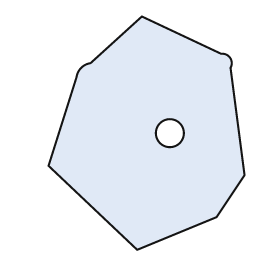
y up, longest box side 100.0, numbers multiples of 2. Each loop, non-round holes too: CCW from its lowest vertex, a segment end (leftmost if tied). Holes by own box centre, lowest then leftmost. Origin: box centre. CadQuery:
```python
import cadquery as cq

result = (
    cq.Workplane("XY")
    .moveTo(-4.0, -50.0)
    .lineTo(30.0, -36.0)
    .lineTo(42.0, -18.0)
    .lineTo(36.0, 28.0)
    .threePointArc((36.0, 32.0), (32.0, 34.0))
    .lineTo(-2.0, 50.0)
    .lineTo(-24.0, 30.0)
    .threePointArc((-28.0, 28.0), (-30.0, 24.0))
    .lineTo(-42.0, -14.0)
    .close()
    .moveTo(10.0, 0.0)
    .circle(6.0)
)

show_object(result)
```